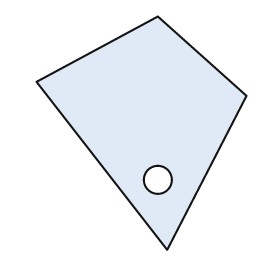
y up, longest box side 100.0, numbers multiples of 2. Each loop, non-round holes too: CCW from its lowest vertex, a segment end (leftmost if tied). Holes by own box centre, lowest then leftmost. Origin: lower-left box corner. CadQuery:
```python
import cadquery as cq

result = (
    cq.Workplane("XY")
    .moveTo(56.0, 0.0)
    .lineTo(90.0, 66.0)
    .lineTo(52.0, 100.0)
    .lineTo(0.0, 72.0)
    .close()
    .moveTo(52.0, 30.0)
    .circle(6.0)
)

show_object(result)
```